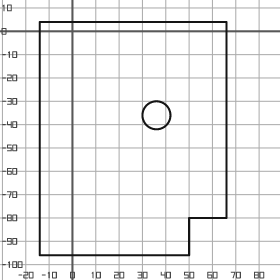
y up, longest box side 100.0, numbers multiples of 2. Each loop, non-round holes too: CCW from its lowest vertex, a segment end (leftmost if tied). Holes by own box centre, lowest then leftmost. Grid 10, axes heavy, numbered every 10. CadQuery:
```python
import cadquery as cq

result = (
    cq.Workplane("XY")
    .moveTo(-14.0, -96.0)
    .lineTo(50.0, -96.0)
    .lineTo(50.0, -80.0)
    .lineTo(66.0, -80.0)
    .lineTo(66.0, 4.0)
    .lineTo(-14.0, 4.0)
    .close()
    .moveTo(36.0, -36.0)
    .circle(6.0)
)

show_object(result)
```